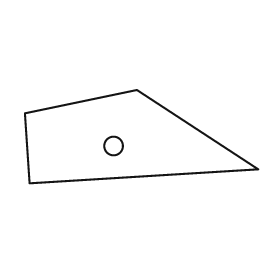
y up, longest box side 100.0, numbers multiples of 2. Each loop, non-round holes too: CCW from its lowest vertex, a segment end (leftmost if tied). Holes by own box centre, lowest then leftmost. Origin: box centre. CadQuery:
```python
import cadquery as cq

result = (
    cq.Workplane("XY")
    .moveTo(-48.0, -20.0)
    .lineTo(50.0, -14.0)
    .lineTo(-2.0, 20.0)
    .lineTo(-50.0, 10.0)
    .close()
    .moveTo(-12.0, -4.0)
    .circle(4.0)
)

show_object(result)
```